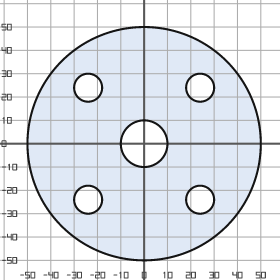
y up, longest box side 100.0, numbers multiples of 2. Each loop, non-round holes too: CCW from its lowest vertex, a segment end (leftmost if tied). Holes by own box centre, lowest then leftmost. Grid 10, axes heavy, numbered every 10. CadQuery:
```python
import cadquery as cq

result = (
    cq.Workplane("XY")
    .moveTo(0.0, 0.0)
    .circle(50.0)
    .moveTo(-24.0, -24.0)
    .circle(6.0)
    .moveTo(24.0, -24.0)
    .circle(6.0)
    .moveTo(0.0, 0.0)
    .circle(10.0)
    .moveTo(-24.0, 24.0)
    .circle(6.0)
    .moveTo(24.0, 24.0)
    .circle(6.0)
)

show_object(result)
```